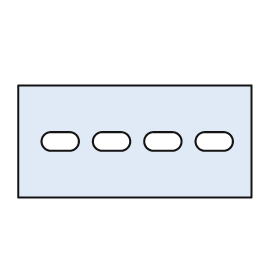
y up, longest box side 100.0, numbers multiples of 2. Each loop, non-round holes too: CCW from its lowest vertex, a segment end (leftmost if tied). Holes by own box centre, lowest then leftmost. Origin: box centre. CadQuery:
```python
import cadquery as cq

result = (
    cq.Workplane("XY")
    .moveTo(-50.0, -24.0)
    .lineTo(50.0, -24.0)
    .lineTo(50.0, 24.0)
    .lineTo(-50.0, 24.0)
    .close()
    .moveTo(-36.0, -4.0)
    .lineTo(-28.0, -4.0)
    .threePointArc((-24.0, 0.0), (-28.0, 4.0))
    .lineTo(-36.0, 4.0)
    .threePointArc((-40.0, 0.0), (-36.0, -4.0))
    .close()
    .moveTo(-14.0, -4.0)
    .lineTo(-6.0, -4.0)
    .threePointArc((-2.0, 0.0), (-6.0, 4.0))
    .lineTo(-14.0, 4.0)
    .threePointArc((-18.0, 0.0), (-14.0, -4.0))
    .close()
    .moveTo(8.0, -4.0)
    .lineTo(16.0, -4.0)
    .threePointArc((20.0, 0.0), (16.0, 4.0))
    .lineTo(8.0, 4.0)
    .threePointArc((4.0, 0.0), (8.0, -4.0))
    .close()
    .moveTo(30.0, -4.0)
    .lineTo(38.0, -4.0)
    .threePointArc((42.0, 0.0), (38.0, 4.0))
    .lineTo(30.0, 4.0)
    .threePointArc((26.0, 0.0), (30.0, -4.0))
    .close()
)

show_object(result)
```